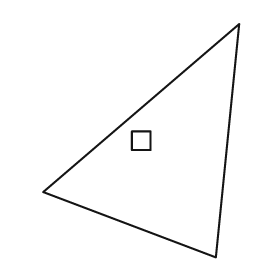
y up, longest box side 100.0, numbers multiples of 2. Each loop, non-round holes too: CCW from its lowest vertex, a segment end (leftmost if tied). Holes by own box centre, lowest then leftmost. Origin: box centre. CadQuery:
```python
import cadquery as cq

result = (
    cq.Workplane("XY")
    .moveTo(32.0, -50.0)
    .lineTo(42.0, 50.0)
    .lineTo(-42.0, -22.0)
    .close()
    .moveTo(-4.0, -4.0)
    .lineTo(4.0, -4.0)
    .lineTo(4.0, 4.0)
    .lineTo(-4.0, 4.0)
    .close()
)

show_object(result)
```